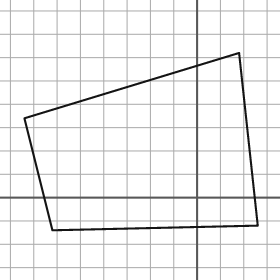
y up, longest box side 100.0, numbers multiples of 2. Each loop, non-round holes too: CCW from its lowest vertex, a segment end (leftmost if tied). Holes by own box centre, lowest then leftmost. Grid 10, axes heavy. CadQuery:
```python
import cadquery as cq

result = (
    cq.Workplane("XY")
    .moveTo(-62.0, -14.0)
    .lineTo(26.0, -12.0)
    .lineTo(18.0, 62.0)
    .lineTo(-74.0, 34.0)
    .close()
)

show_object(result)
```